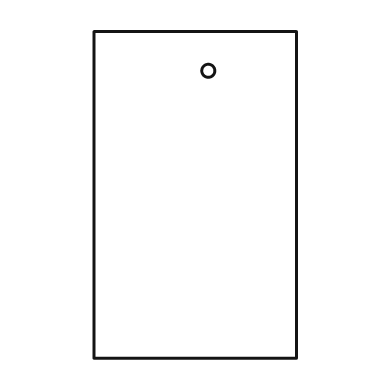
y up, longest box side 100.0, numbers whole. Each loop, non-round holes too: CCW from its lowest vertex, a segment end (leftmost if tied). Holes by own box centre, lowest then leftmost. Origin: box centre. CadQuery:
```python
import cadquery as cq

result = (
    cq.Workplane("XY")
    .moveTo(-31.0, -50.0)
    .lineTo(31.0, -50.0)
    .lineTo(31.0, 50.0)
    .lineTo(-31.0, 50.0)
    .close()
    .moveTo(4.0, 38.0)
    .circle(2.0)
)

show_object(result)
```